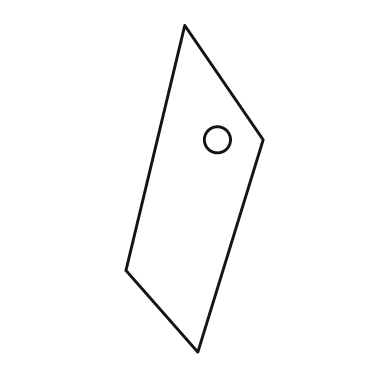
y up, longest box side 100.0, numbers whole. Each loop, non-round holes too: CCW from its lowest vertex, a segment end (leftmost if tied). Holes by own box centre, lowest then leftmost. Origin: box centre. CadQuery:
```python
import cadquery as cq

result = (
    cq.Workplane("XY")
    .moveTo(1.0, -50.0)
    .lineTo(21.0, 15.0)
    .lineTo(-3.0, 50.0)
    .lineTo(-21.0, -25.0)
    .close()
    .moveTo(7.0, 15.0)
    .circle(4.0)
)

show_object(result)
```